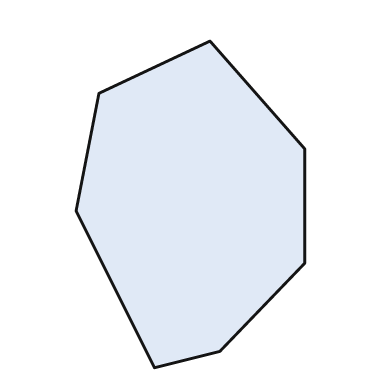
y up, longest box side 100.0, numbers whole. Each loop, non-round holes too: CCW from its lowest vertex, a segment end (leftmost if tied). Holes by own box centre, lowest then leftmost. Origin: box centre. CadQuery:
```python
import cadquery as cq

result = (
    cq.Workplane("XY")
    .moveTo(-11.0, -50.0)
    .lineTo(9.0, -45.0)
    .lineTo(35.0, -18.0)
    .lineTo(35.0, 17.0)
    .lineTo(6.0, 50.0)
    .lineTo(-28.0, 34.0)
    .lineTo(-35.0, -2.0)
    .close()
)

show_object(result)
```